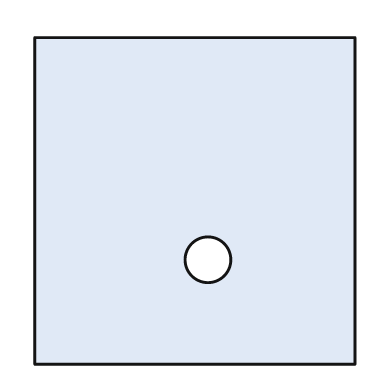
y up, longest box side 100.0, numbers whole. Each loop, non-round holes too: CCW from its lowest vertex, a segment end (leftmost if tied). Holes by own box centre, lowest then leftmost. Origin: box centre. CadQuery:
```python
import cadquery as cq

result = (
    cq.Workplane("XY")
    .moveTo(-49.0, -50.0)
    .lineTo(49.0, -50.0)
    .lineTo(49.0, 50.0)
    .lineTo(-49.0, 50.0)
    .close()
    .moveTo(4.0, -18.0)
    .circle(7.0)
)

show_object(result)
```